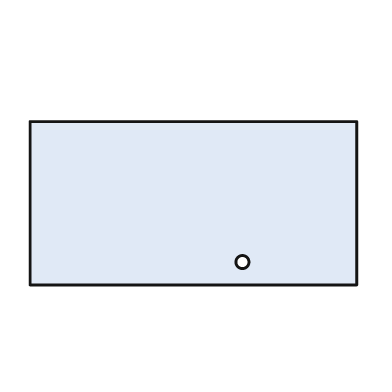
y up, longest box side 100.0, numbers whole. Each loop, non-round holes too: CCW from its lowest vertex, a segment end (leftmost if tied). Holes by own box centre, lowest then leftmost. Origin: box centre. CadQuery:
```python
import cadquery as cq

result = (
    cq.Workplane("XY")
    .moveTo(-50.0, -25.0)
    .lineTo(50.0, -25.0)
    .lineTo(50.0, 25.0)
    .lineTo(-50.0, 25.0)
    .close()
    .moveTo(15.0, -18.0)
    .circle(2.0)
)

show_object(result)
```